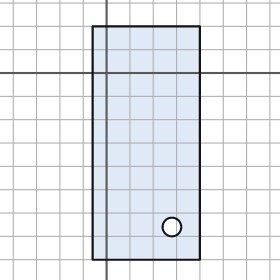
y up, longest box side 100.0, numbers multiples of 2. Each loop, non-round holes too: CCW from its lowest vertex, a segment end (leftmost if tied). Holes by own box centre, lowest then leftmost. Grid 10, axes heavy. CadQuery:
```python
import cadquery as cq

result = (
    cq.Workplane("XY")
    .moveTo(-6.0, -80.0)
    .lineTo(40.0, -80.0)
    .lineTo(40.0, 20.0)
    .lineTo(-6.0, 20.0)
    .close()
    .moveTo(28.0, -66.0)
    .circle(4.0)
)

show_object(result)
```